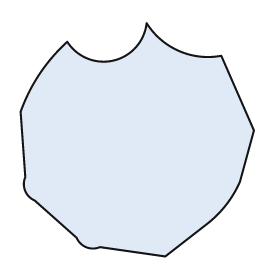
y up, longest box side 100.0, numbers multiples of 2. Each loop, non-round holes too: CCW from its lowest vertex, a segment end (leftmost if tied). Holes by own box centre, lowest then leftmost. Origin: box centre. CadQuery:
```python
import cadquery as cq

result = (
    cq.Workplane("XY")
    .moveTo(12.0, -50.0)
    .lineTo(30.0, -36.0)
    .threePointArc((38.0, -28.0), (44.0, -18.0))
    .lineTo(50.0, 4.0)
    .lineTo(36.0, 36.0)
    .threePointArc((18.0, 38.0), (4.0, 50.0))
    .threePointArc((-10.0, 34.0), (-30.0, 42.0))
    .threePointArc((-42.0, 28.0), (-50.0, 12.0))
    .lineTo(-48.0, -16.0)
    .threePointArc((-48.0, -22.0), (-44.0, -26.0))
    .lineTo(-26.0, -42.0)
    .threePointArc((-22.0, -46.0), (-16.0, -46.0))
    .close()
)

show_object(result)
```